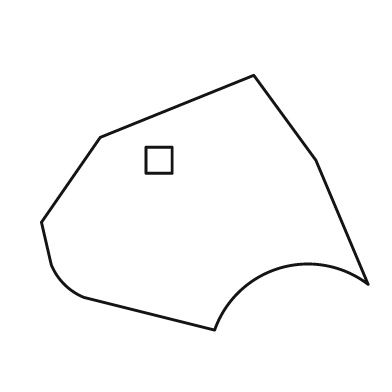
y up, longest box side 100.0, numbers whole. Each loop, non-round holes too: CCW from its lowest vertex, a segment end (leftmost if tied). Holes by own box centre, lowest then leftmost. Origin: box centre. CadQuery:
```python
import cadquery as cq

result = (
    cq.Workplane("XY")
    .moveTo(3.0, -39.0)
    .threePointArc((23.0, -20.0), (50.0, -25.0))
    .lineTo(34.0, 13.0)
    .lineTo(15.0, 39.0)
    .lineTo(-32.0, 20.0)
    .lineTo(-50.0, -6.0)
    .lineTo(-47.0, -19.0)
    .threePointArc((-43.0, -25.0), (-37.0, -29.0))
    .close()
    .moveTo(-18.0, 9.0)
    .lineTo(-10.0, 9.0)
    .lineTo(-10.0, 17.0)
    .lineTo(-18.0, 17.0)
    .close()
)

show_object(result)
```